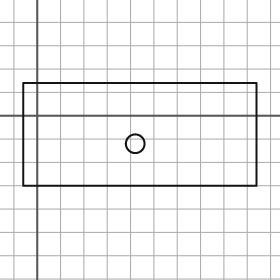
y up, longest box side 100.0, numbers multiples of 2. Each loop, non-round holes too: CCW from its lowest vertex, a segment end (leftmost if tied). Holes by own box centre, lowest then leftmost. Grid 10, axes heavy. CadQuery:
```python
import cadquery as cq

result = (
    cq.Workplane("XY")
    .moveTo(-6.0, -30.0)
    .lineTo(94.0, -30.0)
    .lineTo(94.0, 14.0)
    .lineTo(-6.0, 14.0)
    .close()
    .moveTo(42.0, -12.0)
    .circle(4.0)
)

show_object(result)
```